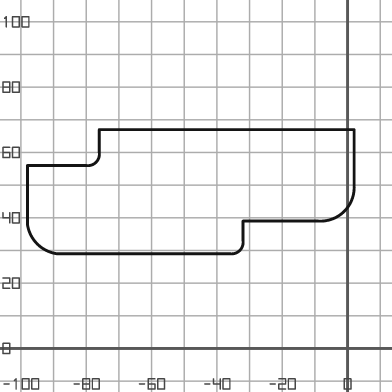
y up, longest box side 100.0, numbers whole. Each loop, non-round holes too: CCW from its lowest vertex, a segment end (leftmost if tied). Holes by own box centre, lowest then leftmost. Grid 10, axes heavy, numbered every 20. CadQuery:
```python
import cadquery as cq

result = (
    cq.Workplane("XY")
    .moveTo(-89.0, 29.0)
    .lineTo(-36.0, 29.0)
    .threePointArc((-33.0, 30.0), (-32.0, 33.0))
    .lineTo(-32.0, 39.0)
    .lineTo(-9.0, 39.0)
    .threePointArc((-1.0, 42.0), (2.0, 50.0))
    .lineTo(2.0, 67.0)
    .lineTo(-76.0, 67.0)
    .lineTo(-76.0, 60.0)
    .threePointArc((-77.0, 57.0), (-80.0, 56.0))
    .lineTo(-98.0, 56.0)
    .lineTo(-98.0, 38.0)
    .threePointArc((-95.0, 32.0), (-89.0, 29.0))
    .close()
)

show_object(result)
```